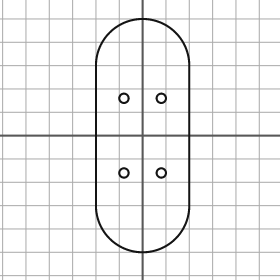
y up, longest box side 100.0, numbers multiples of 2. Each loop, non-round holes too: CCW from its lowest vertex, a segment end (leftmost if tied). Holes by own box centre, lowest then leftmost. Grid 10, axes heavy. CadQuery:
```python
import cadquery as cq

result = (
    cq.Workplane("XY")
    .moveTo(-20.0, -30.0)
    .threePointArc((0.0, -50.0), (20.0, -30.0))
    .lineTo(20.0, 30.0)
    .threePointArc((0.0, 50.0), (-20.0, 30.0))
    .close()
    .moveTo(-8.0, -16.0)
    .circle(2.0)
    .moveTo(8.0, -16.0)
    .circle(2.0)
    .moveTo(-8.0, 16.0)
    .circle(2.0)
    .moveTo(8.0, 16.0)
    .circle(2.0)
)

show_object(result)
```